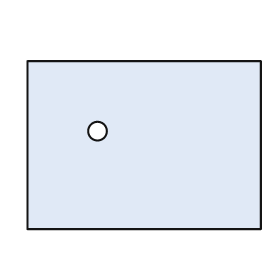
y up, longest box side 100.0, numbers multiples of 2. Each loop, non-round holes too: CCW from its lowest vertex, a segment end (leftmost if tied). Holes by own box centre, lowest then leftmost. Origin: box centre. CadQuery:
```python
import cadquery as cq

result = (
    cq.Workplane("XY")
    .moveTo(-50.0, -36.0)
    .lineTo(50.0, -36.0)
    .lineTo(50.0, 36.0)
    .lineTo(-50.0, 36.0)
    .close()
    .moveTo(-20.0, 6.0)
    .circle(4.0)
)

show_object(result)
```